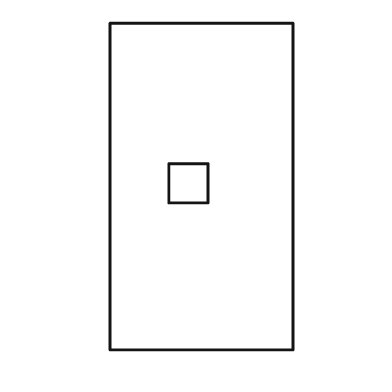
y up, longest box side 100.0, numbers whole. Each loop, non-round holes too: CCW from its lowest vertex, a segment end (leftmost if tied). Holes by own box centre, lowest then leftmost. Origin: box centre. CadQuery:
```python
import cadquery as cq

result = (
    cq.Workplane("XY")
    .moveTo(-28.0, -50.0)
    .lineTo(28.0, -50.0)
    .lineTo(28.0, 50.0)
    .lineTo(-28.0, 50.0)
    .close()
    .moveTo(-10.0, -5.0)
    .lineTo(2.0, -5.0)
    .lineTo(2.0, 7.0)
    .lineTo(-10.0, 7.0)
    .close()
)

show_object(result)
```